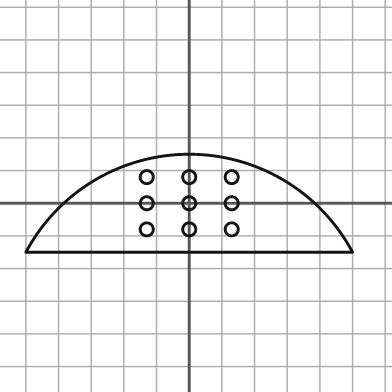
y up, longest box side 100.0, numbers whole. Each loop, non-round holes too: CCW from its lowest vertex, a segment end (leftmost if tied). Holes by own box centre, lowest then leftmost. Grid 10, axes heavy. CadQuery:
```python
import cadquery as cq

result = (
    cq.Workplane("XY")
    .moveTo(-50.0, -15.0)
    .lineTo(50.0, -15.0)
    .threePointArc((0.0, 15.0), (-50.0, -15.0))
    .close()
    .moveTo(-13.0, -8.0)
    .circle(2.0)
    .moveTo(0.0, -8.0)
    .circle(2.0)
    .moveTo(13.0, -8.0)
    .circle(2.0)
    .moveTo(-13.0, 0.0)
    .circle(2.0)
    .moveTo(0.0, 0.0)
    .circle(2.0)
    .moveTo(13.0, 0.0)
    .circle(2.0)
    .moveTo(-13.0, 8.0)
    .circle(2.0)
    .moveTo(0.0, 8.0)
    .circle(2.0)
    .moveTo(13.0, 8.0)
    .circle(2.0)
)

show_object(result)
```